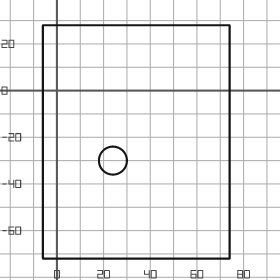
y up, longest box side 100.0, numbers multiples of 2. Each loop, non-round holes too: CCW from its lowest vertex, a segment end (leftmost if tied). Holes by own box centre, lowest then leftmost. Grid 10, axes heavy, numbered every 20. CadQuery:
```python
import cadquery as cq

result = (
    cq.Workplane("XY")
    .moveTo(-6.0, -72.0)
    .lineTo(74.0, -72.0)
    .lineTo(74.0, 28.0)
    .lineTo(-6.0, 28.0)
    .close()
    .moveTo(24.0, -30.0)
    .circle(6.0)
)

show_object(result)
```